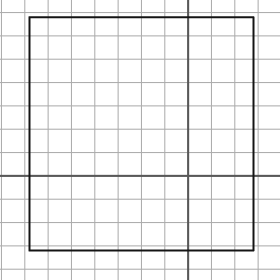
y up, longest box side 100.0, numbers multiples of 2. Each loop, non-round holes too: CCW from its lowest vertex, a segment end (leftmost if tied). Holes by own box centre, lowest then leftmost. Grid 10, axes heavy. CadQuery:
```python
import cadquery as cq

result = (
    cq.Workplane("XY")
    .moveTo(-68.0, -32.0)
    .lineTo(28.0, -32.0)
    .lineTo(28.0, 68.0)
    .lineTo(-68.0, 68.0)
    .close()
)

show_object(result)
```